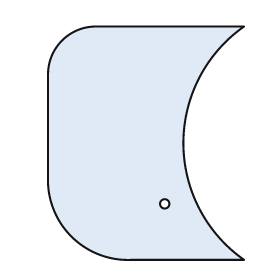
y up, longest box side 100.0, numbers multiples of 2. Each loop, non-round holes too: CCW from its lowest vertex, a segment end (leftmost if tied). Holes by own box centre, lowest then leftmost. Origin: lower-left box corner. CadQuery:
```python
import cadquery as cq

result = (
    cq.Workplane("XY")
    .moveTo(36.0, 0.0)
    .lineTo(84.0, 0.0)
    .threePointArc((58.0, 50.0), (84.0, 100.0))
    .lineTo(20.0, 100.0)
    .threePointArc((6.0, 94.0), (0.0, 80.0))
    .lineTo(0.0, 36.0)
    .threePointArc((10.0, 10.0), (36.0, 0.0))
    .close()
    .moveTo(50.0, 24.0)
    .circle(2.0)
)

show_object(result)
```